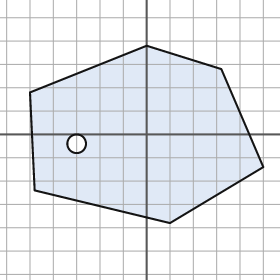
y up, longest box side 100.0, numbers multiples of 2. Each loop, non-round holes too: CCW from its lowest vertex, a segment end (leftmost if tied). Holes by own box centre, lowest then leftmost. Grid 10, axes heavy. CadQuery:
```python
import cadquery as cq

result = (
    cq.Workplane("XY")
    .moveTo(10.0, -38.0)
    .lineTo(50.0, -14.0)
    .lineTo(32.0, 28.0)
    .lineTo(0.0, 38.0)
    .lineTo(-50.0, 18.0)
    .lineTo(-48.0, -24.0)
    .close()
    .moveTo(-30.0, -4.0)
    .circle(4.0)
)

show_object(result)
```